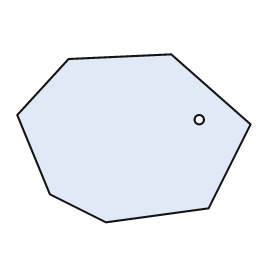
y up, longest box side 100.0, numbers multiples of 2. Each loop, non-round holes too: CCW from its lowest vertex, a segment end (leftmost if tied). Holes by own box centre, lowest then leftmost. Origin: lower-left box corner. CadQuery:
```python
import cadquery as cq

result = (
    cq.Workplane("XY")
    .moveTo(38.0, 0.0)
    .lineTo(82.0, 6.0)
    .lineTo(100.0, 42.0)
    .lineTo(66.0, 72.0)
    .lineTo(22.0, 70.0)
    .lineTo(0.0, 46.0)
    .lineTo(14.0, 12.0)
    .close()
    .moveTo(78.0, 44.0)
    .circle(2.0)
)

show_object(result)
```